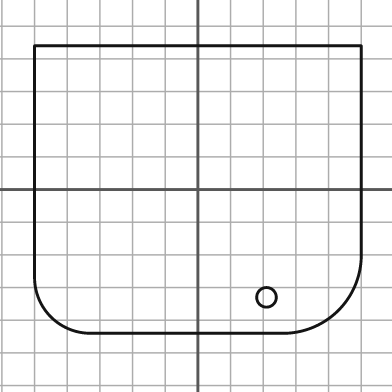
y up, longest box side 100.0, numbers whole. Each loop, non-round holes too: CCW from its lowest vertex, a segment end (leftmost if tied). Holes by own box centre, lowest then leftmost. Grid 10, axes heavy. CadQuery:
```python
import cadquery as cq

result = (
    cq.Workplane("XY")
    .moveTo(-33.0, -44.0)
    .lineTo(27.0, -44.0)
    .threePointArc((43.0, -37.0), (50.0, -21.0))
    .lineTo(50.0, 44.0)
    .lineTo(-50.0, 44.0)
    .lineTo(-50.0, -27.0)
    .threePointArc((-45.0, -39.0), (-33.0, -44.0))
    .close()
    .moveTo(21.0, -33.0)
    .circle(3.0)
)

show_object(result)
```